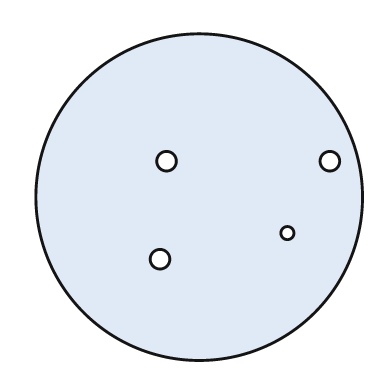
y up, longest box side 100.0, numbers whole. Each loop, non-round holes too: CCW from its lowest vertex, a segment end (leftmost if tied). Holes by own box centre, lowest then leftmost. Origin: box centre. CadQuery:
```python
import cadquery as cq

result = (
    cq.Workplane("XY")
    .moveTo(0.0, 0.0)
    .circle(50.0)
    .moveTo(-12.0, -19.0)
    .circle(3.0)
    .moveTo(27.0, -11.0)
    .circle(2.0)
    .moveTo(-10.0, 11.0)
    .circle(3.0)
    .moveTo(40.0, 11.0)
    .circle(3.0)
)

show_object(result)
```